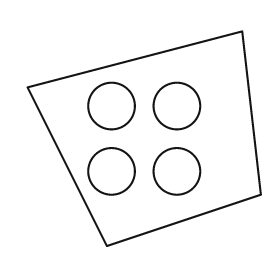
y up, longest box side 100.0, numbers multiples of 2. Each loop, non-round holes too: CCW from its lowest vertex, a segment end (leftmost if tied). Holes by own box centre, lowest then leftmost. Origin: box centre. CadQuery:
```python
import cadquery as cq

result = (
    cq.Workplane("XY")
    .moveTo(-16.0, -46.0)
    .lineTo(50.0, -24.0)
    .lineTo(42.0, 46.0)
    .lineTo(-50.0, 22.0)
    .close()
    .moveTo(-14.0, -14.0)
    .circle(10.0)
    .moveTo(14.0, -14.0)
    .circle(10.0)
    .moveTo(-14.0, 14.0)
    .circle(10.0)
    .moveTo(14.0, 14.0)
    .circle(10.0)
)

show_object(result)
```